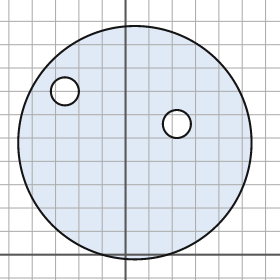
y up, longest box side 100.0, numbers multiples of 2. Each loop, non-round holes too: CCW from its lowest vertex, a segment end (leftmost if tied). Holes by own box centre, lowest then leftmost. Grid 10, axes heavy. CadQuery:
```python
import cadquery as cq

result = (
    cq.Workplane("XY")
    .moveTo(4.0, 48.0)
    .circle(50.0)
    .moveTo(22.0, 56.0)
    .circle(6.0)
    .moveTo(-26.0, 70.0)
    .circle(6.0)
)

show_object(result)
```